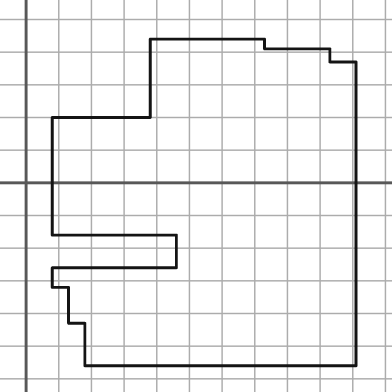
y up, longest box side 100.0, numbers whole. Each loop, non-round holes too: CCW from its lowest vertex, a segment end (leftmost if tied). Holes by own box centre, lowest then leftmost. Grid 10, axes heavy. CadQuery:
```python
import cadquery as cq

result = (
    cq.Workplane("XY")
    .moveTo(18.0, -56.0)
    .lineTo(101.0, -56.0)
    .lineTo(101.0, 37.0)
    .lineTo(93.0, 37.0)
    .lineTo(93.0, 41.0)
    .lineTo(73.0, 41.0)
    .lineTo(73.0, 44.0)
    .lineTo(38.0, 44.0)
    .lineTo(38.0, 20.0)
    .lineTo(8.0, 20.0)
    .lineTo(8.0, -16.0)
    .lineTo(46.0, -16.0)
    .lineTo(46.0, -26.0)
    .lineTo(8.0, -26.0)
    .lineTo(8.0, -32.0)
    .lineTo(13.0, -32.0)
    .lineTo(13.0, -43.0)
    .lineTo(18.0, -43.0)
    .close()
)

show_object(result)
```